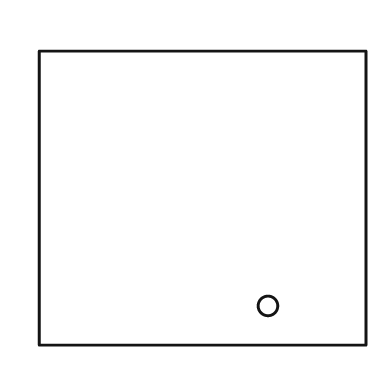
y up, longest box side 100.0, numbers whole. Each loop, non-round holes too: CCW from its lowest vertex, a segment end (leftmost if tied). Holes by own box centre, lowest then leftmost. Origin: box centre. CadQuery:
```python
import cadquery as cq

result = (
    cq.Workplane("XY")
    .moveTo(-50.0, -45.0)
    .lineTo(50.0, -45.0)
    .lineTo(50.0, 45.0)
    .lineTo(-50.0, 45.0)
    .close()
    .moveTo(20.0, -33.0)
    .circle(3.0)
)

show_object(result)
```